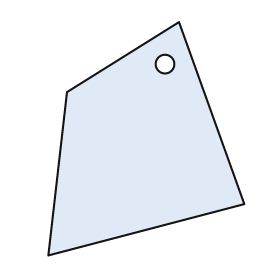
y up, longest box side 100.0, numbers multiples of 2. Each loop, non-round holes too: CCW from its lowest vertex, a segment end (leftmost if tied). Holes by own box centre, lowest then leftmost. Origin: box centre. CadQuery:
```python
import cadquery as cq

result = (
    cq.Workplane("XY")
    .moveTo(-42.0, -50.0)
    .lineTo(42.0, -28.0)
    .lineTo(14.0, 50.0)
    .lineTo(-34.0, 20.0)
    .close()
    .moveTo(8.0, 32.0)
    .circle(4.0)
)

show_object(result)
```